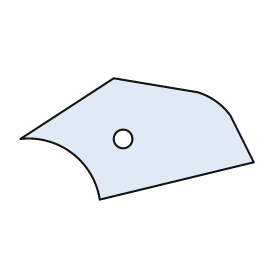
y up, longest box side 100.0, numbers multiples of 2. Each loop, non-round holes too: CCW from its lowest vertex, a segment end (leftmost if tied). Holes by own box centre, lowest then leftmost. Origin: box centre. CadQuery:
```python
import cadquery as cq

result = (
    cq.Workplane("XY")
    .moveTo(-16.0, -26.0)
    .lineTo(50.0, -10.0)
    .lineTo(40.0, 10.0)
    .threePointArc((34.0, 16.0), (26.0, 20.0))
    .lineTo(-10.0, 26.0)
    .lineTo(-50.0, 0.0)
    .threePointArc((-28.0, -6.0), (-16.0, -26.0))
    .close()
    .moveTo(-6.0, 0.0)
    .circle(4.0)
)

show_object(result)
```